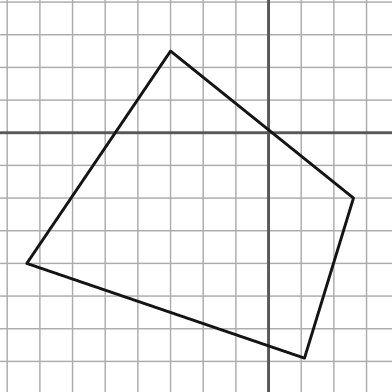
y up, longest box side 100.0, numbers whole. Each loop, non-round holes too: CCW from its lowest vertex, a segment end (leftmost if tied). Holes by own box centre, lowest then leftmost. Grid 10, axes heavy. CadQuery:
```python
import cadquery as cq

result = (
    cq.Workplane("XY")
    .moveTo(11.0, -69.0)
    .lineTo(26.0, -20.0)
    .lineTo(-30.0, 25.0)
    .lineTo(-74.0, -40.0)
    .close()
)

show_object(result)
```